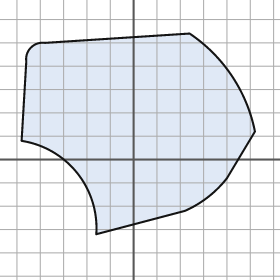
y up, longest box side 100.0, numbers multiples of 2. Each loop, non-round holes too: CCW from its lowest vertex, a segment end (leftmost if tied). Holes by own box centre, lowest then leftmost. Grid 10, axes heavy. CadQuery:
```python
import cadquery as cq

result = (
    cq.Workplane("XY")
    .moveTo(-16.0, -32.0)
    .lineTo(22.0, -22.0)
    .threePointArc((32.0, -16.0), (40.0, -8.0))
    .lineTo(52.0, 12.0)
    .threePointArc((42.0, 36.0), (24.0, 54.0))
    .lineTo(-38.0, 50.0)
    .threePointArc((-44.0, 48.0), (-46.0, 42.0))
    .lineTo(-48.0, 8.0)
    .threePointArc((-24.0, -6.0), (-16.0, -32.0))
    .close()
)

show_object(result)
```